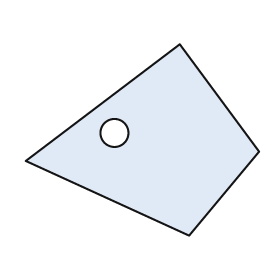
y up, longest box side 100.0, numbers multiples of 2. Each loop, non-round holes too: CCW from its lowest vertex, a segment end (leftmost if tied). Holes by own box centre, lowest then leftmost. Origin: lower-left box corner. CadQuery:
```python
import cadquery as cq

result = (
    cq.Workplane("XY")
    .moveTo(70.0, 0.0)
    .lineTo(100.0, 36.0)
    .lineTo(66.0, 82.0)
    .lineTo(0.0, 32.0)
    .close()
    .moveTo(38.0, 44.0)
    .circle(6.0)
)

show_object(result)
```